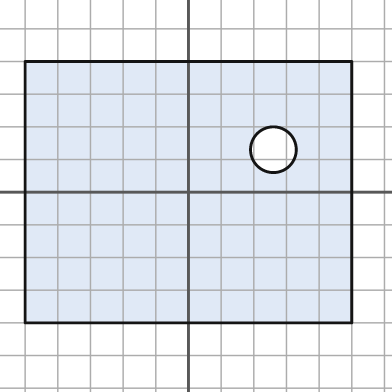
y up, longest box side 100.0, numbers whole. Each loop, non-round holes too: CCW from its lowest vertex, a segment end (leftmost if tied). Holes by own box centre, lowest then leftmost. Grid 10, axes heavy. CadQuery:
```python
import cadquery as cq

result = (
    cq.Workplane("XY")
    .moveTo(-50.0, -40.0)
    .lineTo(50.0, -40.0)
    .lineTo(50.0, 40.0)
    .lineTo(-50.0, 40.0)
    .close()
    .moveTo(26.0, 13.0)
    .circle(7.0)
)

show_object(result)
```